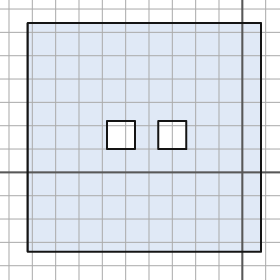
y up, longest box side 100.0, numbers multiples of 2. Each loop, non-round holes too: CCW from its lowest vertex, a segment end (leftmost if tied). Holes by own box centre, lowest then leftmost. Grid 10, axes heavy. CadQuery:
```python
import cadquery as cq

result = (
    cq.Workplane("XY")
    .moveTo(-92.0, -34.0)
    .lineTo(8.0, -34.0)
    .lineTo(8.0, 64.0)
    .lineTo(-92.0, 64.0)
    .close()
    .moveTo(-58.0, 10.0)
    .lineTo(-46.0, 10.0)
    .lineTo(-46.0, 22.0)
    .lineTo(-58.0, 22.0)
    .close()
    .moveTo(-36.0, 10.0)
    .lineTo(-24.0, 10.0)
    .lineTo(-24.0, 22.0)
    .lineTo(-36.0, 22.0)
    .close()
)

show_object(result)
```